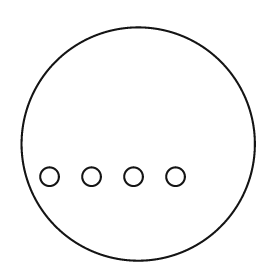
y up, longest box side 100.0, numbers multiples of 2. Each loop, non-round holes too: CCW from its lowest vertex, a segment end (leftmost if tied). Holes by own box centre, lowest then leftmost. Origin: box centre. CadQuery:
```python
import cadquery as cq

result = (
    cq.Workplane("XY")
    .moveTo(0.0, 0.0)
    .circle(50.0)
    .moveTo(-38.0, -14.0)
    .circle(4.0)
    .moveTo(-20.0, -14.0)
    .circle(4.0)
    .moveTo(-2.0, -14.0)
    .circle(4.0)
    .moveTo(16.0, -14.0)
    .circle(4.0)
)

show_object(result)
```